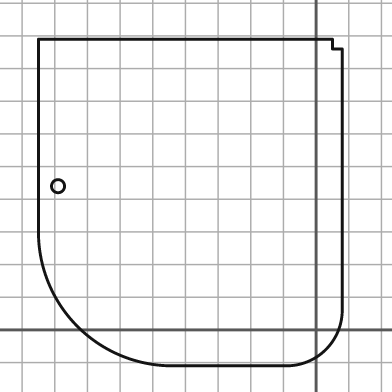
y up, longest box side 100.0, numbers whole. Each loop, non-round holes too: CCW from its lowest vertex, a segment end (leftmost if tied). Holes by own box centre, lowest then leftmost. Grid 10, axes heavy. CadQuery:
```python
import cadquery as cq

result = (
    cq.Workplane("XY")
    .moveTo(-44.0, -11.0)
    .lineTo(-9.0, -11.0)
    .threePointArc((3.0, -6.0), (8.0, 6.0))
    .lineTo(8.0, 86.0)
    .lineTo(5.0, 86.0)
    .lineTo(5.0, 89.0)
    .lineTo(-85.0, 89.0)
    .lineTo(-85.0, 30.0)
    .threePointArc((-73.0, 1.0), (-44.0, -11.0))
    .close()
    .moveTo(-79.0, 44.0)
    .circle(2.0)
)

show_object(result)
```